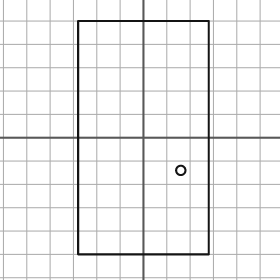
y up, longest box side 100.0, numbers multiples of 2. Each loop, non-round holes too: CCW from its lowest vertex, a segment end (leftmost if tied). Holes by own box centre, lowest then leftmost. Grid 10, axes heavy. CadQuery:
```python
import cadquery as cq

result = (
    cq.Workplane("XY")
    .moveTo(-28.0, -50.0)
    .lineTo(28.0, -50.0)
    .lineTo(28.0, 50.0)
    .lineTo(-28.0, 50.0)
    .close()
    .moveTo(16.0, -14.0)
    .circle(2.0)
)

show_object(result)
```